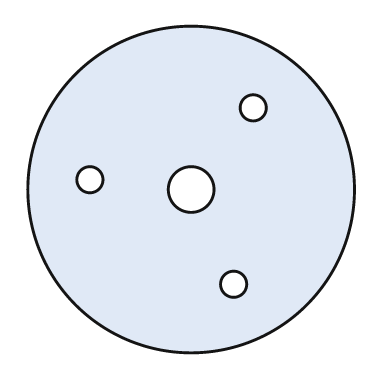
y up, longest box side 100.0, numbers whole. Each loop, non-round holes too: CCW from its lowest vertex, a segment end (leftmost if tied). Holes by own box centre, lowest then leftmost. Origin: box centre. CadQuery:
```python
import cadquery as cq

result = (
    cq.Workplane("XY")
    .moveTo(0.0, 0.0)
    .circle(50.0)
    .moveTo(13.0, -29.0)
    .circle(4.0)
    .moveTo(0.0, 0.0)
    .circle(7.0)
    .moveTo(-31.0, 3.0)
    .circle(4.0)
    .moveTo(19.0, 25.0)
    .circle(4.0)
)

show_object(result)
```